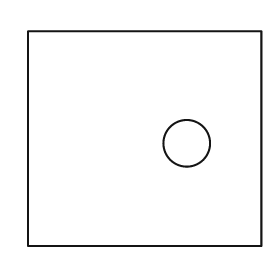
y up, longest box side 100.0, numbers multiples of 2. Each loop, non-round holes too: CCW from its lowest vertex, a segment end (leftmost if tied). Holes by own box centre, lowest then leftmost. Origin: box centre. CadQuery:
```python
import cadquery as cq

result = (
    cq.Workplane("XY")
    .moveTo(-50.0, -46.0)
    .lineTo(50.0, -46.0)
    .lineTo(50.0, 46.0)
    .lineTo(-50.0, 46.0)
    .close()
    .moveTo(18.0, -2.0)
    .circle(10.0)
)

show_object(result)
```